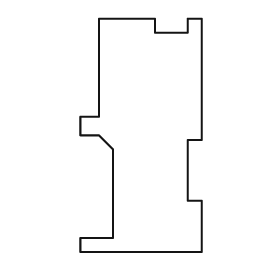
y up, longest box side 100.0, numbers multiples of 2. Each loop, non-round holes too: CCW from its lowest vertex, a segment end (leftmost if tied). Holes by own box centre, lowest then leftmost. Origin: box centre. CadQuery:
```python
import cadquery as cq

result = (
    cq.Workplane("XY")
    .moveTo(-26.0, -50.0)
    .lineTo(26.0, -50.0)
    .lineTo(26.0, -28.0)
    .lineTo(20.0, -28.0)
    .lineTo(20.0, -2.0)
    .lineTo(26.0, -2.0)
    .lineTo(26.0, 50.0)
    .lineTo(20.0, 50.0)
    .lineTo(20.0, 44.0)
    .lineTo(6.0, 44.0)
    .lineTo(6.0, 50.0)
    .lineTo(-18.0, 50.0)
    .lineTo(-18.0, 8.0)
    .lineTo(-26.0, 8.0)
    .lineTo(-26.0, 0.0)
    .lineTo(-18.0, 0.0)
    .lineTo(-12.0, -6.0)
    .lineTo(-12.0, -44.0)
    .lineTo(-26.0, -44.0)
    .close()
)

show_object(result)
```